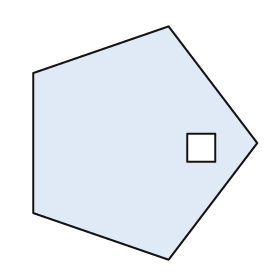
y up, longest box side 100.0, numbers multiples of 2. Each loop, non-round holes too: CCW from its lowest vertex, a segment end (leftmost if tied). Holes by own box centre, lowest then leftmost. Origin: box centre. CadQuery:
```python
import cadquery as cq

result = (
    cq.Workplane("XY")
    .moveTo(10.0, -50.0)
    .lineTo(48.0, 0.0)
    .lineTo(10.0, 50.0)
    .lineTo(-48.0, 30.0)
    .lineTo(-48.0, -30.0)
    .close()
    .moveTo(18.0, -8.0)
    .lineTo(30.0, -8.0)
    .lineTo(30.0, 4.0)
    .lineTo(18.0, 4.0)
    .close()
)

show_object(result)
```